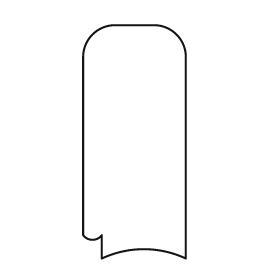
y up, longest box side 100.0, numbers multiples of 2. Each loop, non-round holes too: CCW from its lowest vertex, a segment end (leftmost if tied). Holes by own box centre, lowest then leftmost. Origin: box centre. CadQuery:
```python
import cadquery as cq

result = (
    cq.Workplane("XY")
    .moveTo(-14.0, -50.0)
    .threePointArc((4.0, -46.0), (22.0, -50.0))
    .lineTo(22.0, 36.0)
    .threePointArc((18.0, 46.0), (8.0, 50.0))
    .lineTo(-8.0, 50.0)
    .threePointArc((-18.0, 46.0), (-22.0, 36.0))
    .lineTo(-22.0, -40.0)
    .threePointArc((-18.0, -42.0), (-14.0, -40.0))
    .close()
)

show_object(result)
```